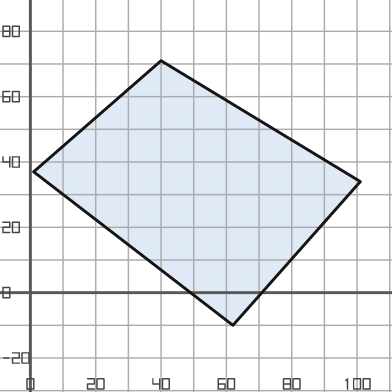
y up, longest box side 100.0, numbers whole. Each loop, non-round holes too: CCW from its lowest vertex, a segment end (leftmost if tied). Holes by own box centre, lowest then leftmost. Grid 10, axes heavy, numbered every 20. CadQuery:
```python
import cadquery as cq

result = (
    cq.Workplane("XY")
    .moveTo(62.0, -10.0)
    .lineTo(101.0, 34.0)
    .lineTo(40.0, 71.0)
    .lineTo(1.0, 37.0)
    .close()
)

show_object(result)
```